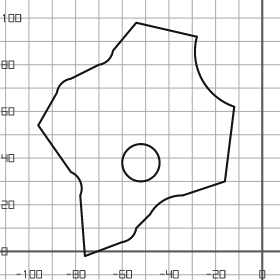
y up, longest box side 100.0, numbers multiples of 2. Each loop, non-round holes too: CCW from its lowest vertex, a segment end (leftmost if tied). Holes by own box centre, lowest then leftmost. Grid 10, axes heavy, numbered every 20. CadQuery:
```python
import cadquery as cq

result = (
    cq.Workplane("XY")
    .moveTo(-76.0, -2.0)
    .lineTo(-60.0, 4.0)
    .threePointArc((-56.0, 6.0), (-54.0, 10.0))
    .lineTo(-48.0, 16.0)
    .threePointArc((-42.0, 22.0), (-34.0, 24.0))
    .lineTo(-16.0, 30.0)
    .lineTo(-12.0, 62.0)
    .threePointArc((-26.0, 74.0), (-28.0, 92.0))
    .lineTo(-54.0, 98.0)
    .lineTo(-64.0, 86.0)
    .threePointArc((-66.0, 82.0), (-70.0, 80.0))
    .lineTo(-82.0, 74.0)
    .threePointArc((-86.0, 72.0), (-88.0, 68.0))
    .lineTo(-96.0, 54.0)
    .lineTo(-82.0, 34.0)
    .threePointArc((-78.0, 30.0), (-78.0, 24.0))
    .close()
    .moveTo(-52.0, 38.0)
    .circle(8.0)
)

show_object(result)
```